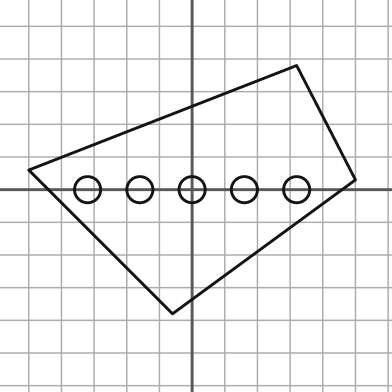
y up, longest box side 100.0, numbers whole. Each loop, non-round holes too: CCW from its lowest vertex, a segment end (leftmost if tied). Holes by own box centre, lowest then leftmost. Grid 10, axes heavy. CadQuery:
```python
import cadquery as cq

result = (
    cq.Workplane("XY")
    .moveTo(-6.0, -38.0)
    .lineTo(50.0, 3.0)
    .lineTo(32.0, 38.0)
    .lineTo(-50.0, 6.0)
    .close()
    .moveTo(-32.0, 0.0)
    .circle(4.0)
    .moveTo(-16.0, 0.0)
    .circle(4.0)
    .moveTo(0.0, 0.0)
    .circle(4.0)
    .moveTo(16.0, 0.0)
    .circle(4.0)
    .moveTo(32.0, 0.0)
    .circle(4.0)
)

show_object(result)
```